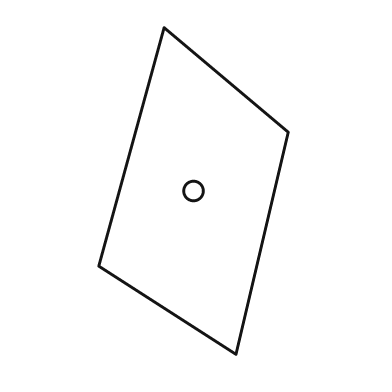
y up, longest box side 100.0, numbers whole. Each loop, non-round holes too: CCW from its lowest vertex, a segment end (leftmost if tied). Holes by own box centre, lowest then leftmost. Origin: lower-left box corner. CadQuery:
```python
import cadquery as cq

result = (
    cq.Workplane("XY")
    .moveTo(42.0, 0.0)
    .lineTo(58.0, 68.0)
    .lineTo(20.0, 100.0)
    .lineTo(0.0, 27.0)
    .close()
    .moveTo(29.0, 50.0)
    .circle(3.0)
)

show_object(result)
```